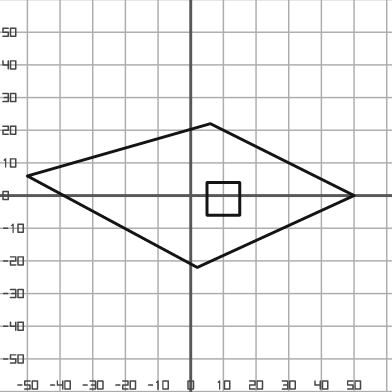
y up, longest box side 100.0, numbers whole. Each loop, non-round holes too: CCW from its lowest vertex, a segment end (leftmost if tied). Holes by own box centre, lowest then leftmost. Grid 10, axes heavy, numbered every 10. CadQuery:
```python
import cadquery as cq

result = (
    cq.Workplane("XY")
    .moveTo(2.0, -22.0)
    .lineTo(50.0, 0.0)
    .lineTo(6.0, 22.0)
    .lineTo(-50.0, 6.0)
    .close()
    .moveTo(5.0, -6.0)
    .lineTo(15.0, -6.0)
    .lineTo(15.0, 4.0)
    .lineTo(5.0, 4.0)
    .close()
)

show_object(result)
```